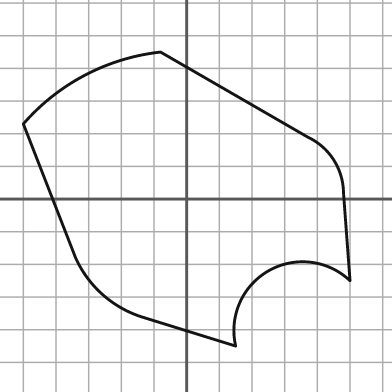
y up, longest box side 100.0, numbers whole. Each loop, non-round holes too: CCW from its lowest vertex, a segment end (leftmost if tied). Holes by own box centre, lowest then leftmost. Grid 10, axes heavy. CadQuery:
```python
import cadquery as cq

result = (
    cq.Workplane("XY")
    .moveTo(15.0, -45.0)
    .threePointArc((25.0, -22.0), (50.0, -25.0))
    .lineTo(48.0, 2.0)
    .threePointArc((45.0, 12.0), (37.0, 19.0))
    .lineTo(-8.0, 45.0)
    .threePointArc((-31.0, 38.0), (-50.0, 23.0))
    .lineTo(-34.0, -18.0)
    .threePointArc((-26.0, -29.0), (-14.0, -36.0))
    .close()
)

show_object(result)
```